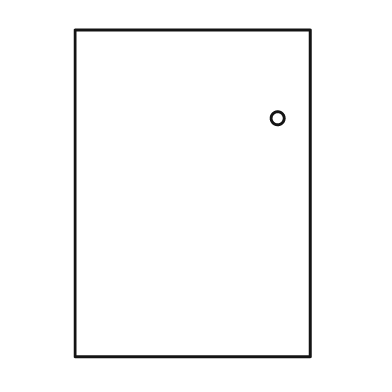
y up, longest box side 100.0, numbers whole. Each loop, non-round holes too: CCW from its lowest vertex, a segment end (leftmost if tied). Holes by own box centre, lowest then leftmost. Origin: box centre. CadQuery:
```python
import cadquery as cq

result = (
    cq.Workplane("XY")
    .moveTo(-36.0, -50.0)
    .lineTo(36.0, -50.0)
    .lineTo(36.0, 50.0)
    .lineTo(-36.0, 50.0)
    .close()
    .moveTo(26.0, 23.0)
    .circle(2.0)
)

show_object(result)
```